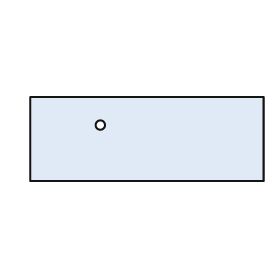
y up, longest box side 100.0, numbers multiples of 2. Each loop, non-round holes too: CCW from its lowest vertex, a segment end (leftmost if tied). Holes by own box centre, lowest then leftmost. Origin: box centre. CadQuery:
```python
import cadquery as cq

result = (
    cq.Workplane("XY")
    .moveTo(-50.0, -18.0)
    .lineTo(50.0, -18.0)
    .lineTo(50.0, 18.0)
    .lineTo(-50.0, 18.0)
    .close()
    .moveTo(-20.0, 6.0)
    .circle(2.0)
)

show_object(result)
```